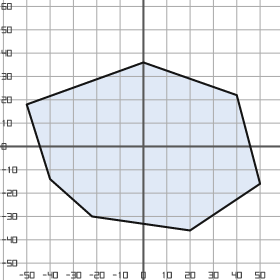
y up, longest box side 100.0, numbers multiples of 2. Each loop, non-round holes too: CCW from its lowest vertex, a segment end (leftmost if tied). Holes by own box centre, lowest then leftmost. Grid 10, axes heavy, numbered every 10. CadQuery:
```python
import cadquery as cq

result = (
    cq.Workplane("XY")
    .moveTo(20.0, -36.0)
    .lineTo(50.0, -16.0)
    .lineTo(40.0, 22.0)
    .lineTo(0.0, 36.0)
    .lineTo(-50.0, 18.0)
    .lineTo(-40.0, -14.0)
    .lineTo(-22.0, -30.0)
    .close()
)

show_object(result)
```